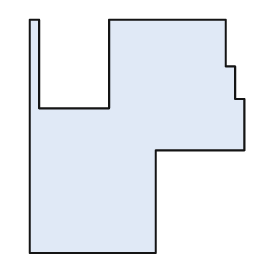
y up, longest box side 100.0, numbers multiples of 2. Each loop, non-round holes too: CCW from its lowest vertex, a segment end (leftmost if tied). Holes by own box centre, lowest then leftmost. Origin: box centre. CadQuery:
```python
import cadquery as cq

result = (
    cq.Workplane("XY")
    .moveTo(-46.0, -50.0)
    .lineTo(8.0, -50.0)
    .lineTo(8.0, -6.0)
    .lineTo(46.0, -6.0)
    .lineTo(46.0, 16.0)
    .lineTo(42.0, 16.0)
    .lineTo(42.0, 30.0)
    .lineTo(38.0, 30.0)
    .lineTo(38.0, 50.0)
    .lineTo(-12.0, 50.0)
    .lineTo(-12.0, 12.0)
    .lineTo(-42.0, 12.0)
    .lineTo(-42.0, 50.0)
    .lineTo(-46.0, 50.0)
    .close()
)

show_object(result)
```